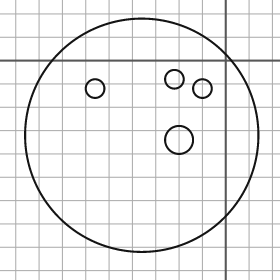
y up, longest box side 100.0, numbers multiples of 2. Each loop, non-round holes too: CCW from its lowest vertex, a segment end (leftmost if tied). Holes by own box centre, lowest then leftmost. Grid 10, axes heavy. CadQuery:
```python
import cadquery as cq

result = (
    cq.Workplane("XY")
    .moveTo(-36.0, -32.0)
    .circle(50.0)
    .moveTo(-20.0, -34.0)
    .circle(6.0)
    .moveTo(-56.0, -12.0)
    .circle(4.0)
    .moveTo(-10.0, -12.0)
    .circle(4.0)
    .moveTo(-22.0, -8.0)
    .circle(4.0)
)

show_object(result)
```